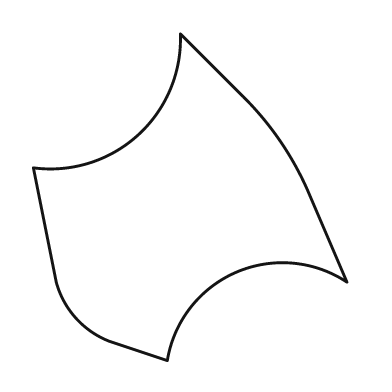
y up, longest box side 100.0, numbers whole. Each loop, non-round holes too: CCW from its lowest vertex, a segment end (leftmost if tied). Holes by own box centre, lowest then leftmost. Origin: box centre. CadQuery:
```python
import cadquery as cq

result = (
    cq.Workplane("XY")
    .moveTo(-7.0, -50.0)
    .threePointArc((14.0, -23.0), (48.0, -26.0))
    .lineTo(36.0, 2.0)
    .threePointArc((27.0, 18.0), (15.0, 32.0))
    .lineTo(-3.0, 50.0)
    .threePointArc((-16.0, 19.0), (-48.0, 9.0))
    .lineTo(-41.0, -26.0)
    .threePointArc((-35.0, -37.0), (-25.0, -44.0))
    .close()
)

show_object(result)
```